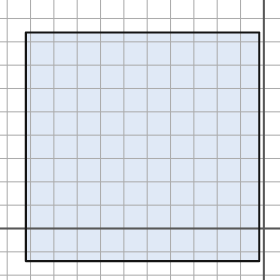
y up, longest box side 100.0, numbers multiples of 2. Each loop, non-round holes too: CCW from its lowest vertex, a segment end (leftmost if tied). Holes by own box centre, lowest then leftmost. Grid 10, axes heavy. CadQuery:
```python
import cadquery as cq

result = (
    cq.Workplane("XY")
    .moveTo(-102.0, -14.0)
    .lineTo(-2.0, -14.0)
    .lineTo(-2.0, 84.0)
    .lineTo(-102.0, 84.0)
    .close()
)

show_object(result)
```